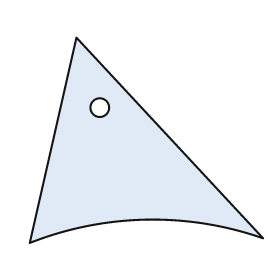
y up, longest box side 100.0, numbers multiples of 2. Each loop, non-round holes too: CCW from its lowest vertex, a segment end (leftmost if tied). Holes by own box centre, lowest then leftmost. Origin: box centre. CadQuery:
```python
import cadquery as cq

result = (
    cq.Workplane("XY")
    .moveTo(-50.0, -44.0)
    .threePointArc((0.0, -34.0), (50.0, -42.0))
    .lineTo(-30.0, 44.0)
    .close()
    .moveTo(-20.0, 14.0)
    .circle(4.0)
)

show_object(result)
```